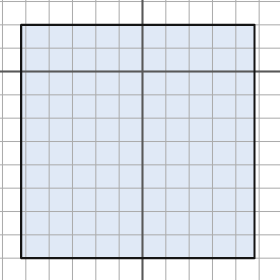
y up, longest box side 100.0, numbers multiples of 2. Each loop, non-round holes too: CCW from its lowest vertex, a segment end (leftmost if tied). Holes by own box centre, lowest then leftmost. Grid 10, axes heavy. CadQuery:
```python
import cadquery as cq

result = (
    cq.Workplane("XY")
    .moveTo(-52.0, -80.0)
    .lineTo(48.0, -80.0)
    .lineTo(48.0, 20.0)
    .lineTo(-52.0, 20.0)
    .close()
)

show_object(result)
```